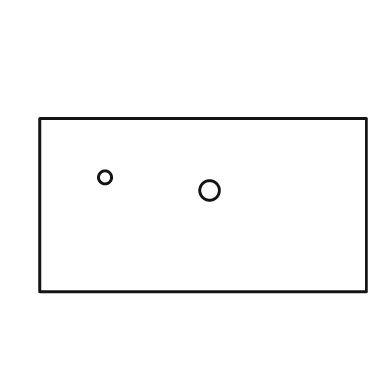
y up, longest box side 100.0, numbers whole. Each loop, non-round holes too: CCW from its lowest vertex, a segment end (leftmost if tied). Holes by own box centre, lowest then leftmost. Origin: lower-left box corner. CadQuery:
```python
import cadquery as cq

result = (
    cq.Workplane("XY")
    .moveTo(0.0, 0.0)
    .lineTo(100.0, 0.0)
    .lineTo(100.0, 53.0)
    .lineTo(0.0, 53.0)
    .close()
    .moveTo(52.0, 31.0)
    .circle(3.0)
    .moveTo(20.0, 35.0)
    .circle(2.0)
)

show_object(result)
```